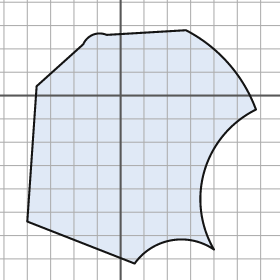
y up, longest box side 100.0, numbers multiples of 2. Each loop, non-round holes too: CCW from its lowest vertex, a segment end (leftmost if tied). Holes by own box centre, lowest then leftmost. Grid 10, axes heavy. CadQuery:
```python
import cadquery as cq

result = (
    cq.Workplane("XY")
    .moveTo(6.0, -72.0)
    .threePointArc((22.0, -62.0), (40.0, -66.0))
    .threePointArc((36.0, -32.0), (58.0, -6.0))
    .threePointArc((46.0, 14.0), (28.0, 28.0))
    .lineTo(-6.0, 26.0)
    .threePointArc((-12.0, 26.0), (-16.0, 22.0))
    .lineTo(-36.0, 4.0)
    .lineTo(-40.0, -54.0)
    .close()
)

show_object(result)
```